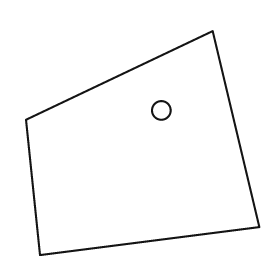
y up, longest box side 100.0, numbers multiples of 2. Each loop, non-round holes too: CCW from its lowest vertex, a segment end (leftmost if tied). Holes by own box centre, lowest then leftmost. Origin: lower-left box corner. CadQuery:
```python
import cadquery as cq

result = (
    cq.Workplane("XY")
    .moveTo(6.0, 0.0)
    .lineTo(100.0, 12.0)
    .lineTo(80.0, 96.0)
    .lineTo(0.0, 58.0)
    .close()
    .moveTo(58.0, 62.0)
    .circle(4.0)
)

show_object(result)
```